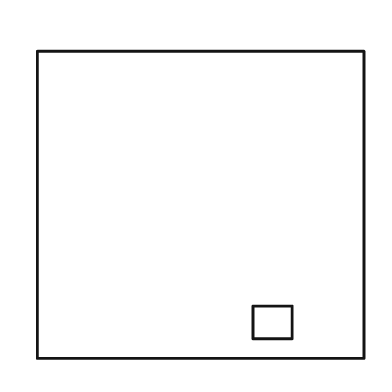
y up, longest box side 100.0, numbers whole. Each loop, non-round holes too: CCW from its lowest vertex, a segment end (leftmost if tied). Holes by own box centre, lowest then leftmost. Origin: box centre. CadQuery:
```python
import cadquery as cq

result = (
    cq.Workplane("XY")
    .moveTo(-50.0, -47.0)
    .lineTo(50.0, -47.0)
    .lineTo(50.0, 47.0)
    .lineTo(-50.0, 47.0)
    .close()
    .moveTo(16.0, -41.0)
    .lineTo(28.0, -41.0)
    .lineTo(28.0, -31.0)
    .lineTo(16.0, -31.0)
    .close()
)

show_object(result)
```